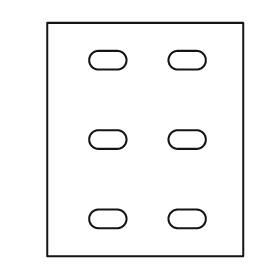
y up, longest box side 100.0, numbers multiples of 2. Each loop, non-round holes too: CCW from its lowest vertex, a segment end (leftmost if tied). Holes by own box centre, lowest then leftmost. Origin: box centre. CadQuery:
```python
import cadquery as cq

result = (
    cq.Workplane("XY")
    .moveTo(-42.0, -50.0)
    .lineTo(42.0, -50.0)
    .lineTo(42.0, 50.0)
    .lineTo(-42.0, 50.0)
    .close()
    .moveTo(-20.0, -38.0)
    .lineTo(-12.0, -38.0)
    .threePointArc((-8.0, -34.0), (-12.0, -30.0))
    .lineTo(-20.0, -30.0)
    .threePointArc((-24.0, -34.0), (-20.0, -38.0))
    .close()
    .moveTo(14.0, -38.0)
    .lineTo(22.0, -38.0)
    .threePointArc((26.0, -34.0), (22.0, -30.0))
    .lineTo(14.0, -30.0)
    .threePointArc((10.0, -34.0), (14.0, -38.0))
    .close()
    .moveTo(-20.0, -4.0)
    .lineTo(-12.0, -4.0)
    .threePointArc((-8.0, 0.0), (-12.0, 4.0))
    .lineTo(-20.0, 4.0)
    .threePointArc((-24.0, 0.0), (-20.0, -4.0))
    .close()
    .moveTo(14.0, -4.0)
    .lineTo(22.0, -4.0)
    .threePointArc((26.0, 0.0), (22.0, 4.0))
    .lineTo(14.0, 4.0)
    .threePointArc((10.0, 0.0), (14.0, -4.0))
    .close()
    .moveTo(-20.0, 30.0)
    .lineTo(-12.0, 30.0)
    .threePointArc((-8.0, 34.0), (-12.0, 38.0))
    .lineTo(-20.0, 38.0)
    .threePointArc((-24.0, 34.0), (-20.0, 30.0))
    .close()
    .moveTo(14.0, 30.0)
    .lineTo(22.0, 30.0)
    .threePointArc((26.0, 34.0), (22.0, 38.0))
    .lineTo(14.0, 38.0)
    .threePointArc((10.0, 34.0), (14.0, 30.0))
    .close()
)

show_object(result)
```